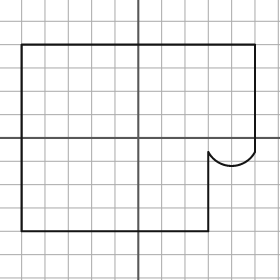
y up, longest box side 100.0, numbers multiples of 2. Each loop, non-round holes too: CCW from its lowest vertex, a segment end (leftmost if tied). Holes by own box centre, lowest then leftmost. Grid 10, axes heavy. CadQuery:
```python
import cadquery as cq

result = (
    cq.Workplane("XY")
    .moveTo(-50.0, -40.0)
    .lineTo(30.0, -40.0)
    .lineTo(30.0, -6.0)
    .threePointArc((40.0, -12.0), (50.0, -6.0))
    .lineTo(50.0, 40.0)
    .lineTo(-50.0, 40.0)
    .close()
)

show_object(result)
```